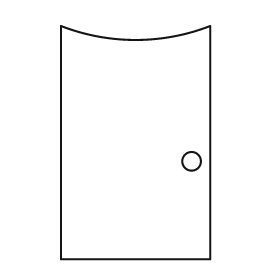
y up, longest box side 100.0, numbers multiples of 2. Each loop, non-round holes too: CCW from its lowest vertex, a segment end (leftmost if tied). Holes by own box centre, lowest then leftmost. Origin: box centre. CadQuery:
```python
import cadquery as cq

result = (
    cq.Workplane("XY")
    .moveTo(-32.0, -50.0)
    .lineTo(32.0, -50.0)
    .lineTo(32.0, 50.0)
    .threePointArc((0.0, 44.0), (-32.0, 50.0))
    .close()
    .moveTo(24.0, -8.0)
    .circle(4.0)
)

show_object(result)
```